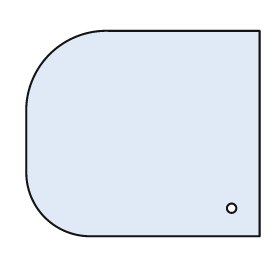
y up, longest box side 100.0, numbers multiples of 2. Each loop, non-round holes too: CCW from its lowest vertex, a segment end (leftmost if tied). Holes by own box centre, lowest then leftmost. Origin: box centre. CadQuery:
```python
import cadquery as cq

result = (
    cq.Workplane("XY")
    .moveTo(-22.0, -44.0)
    .lineTo(50.0, -44.0)
    .lineTo(50.0, 44.0)
    .lineTo(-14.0, 44.0)
    .threePointArc((-40.0, 34.0), (-50.0, 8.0))
    .lineTo(-50.0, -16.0)
    .threePointArc((-42.0, -36.0), (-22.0, -44.0))
    .close()
    .moveTo(38.0, -32.0)
    .circle(2.0)
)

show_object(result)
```